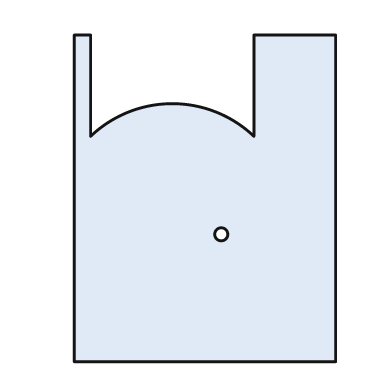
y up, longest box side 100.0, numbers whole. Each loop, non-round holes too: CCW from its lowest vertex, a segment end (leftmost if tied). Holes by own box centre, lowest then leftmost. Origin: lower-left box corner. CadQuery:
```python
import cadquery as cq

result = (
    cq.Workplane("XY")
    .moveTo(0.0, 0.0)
    .lineTo(80.0, 0.0)
    .lineTo(80.0, 100.0)
    .lineTo(55.0, 100.0)
    .lineTo(55.0, 69.0)
    .threePointArc((30.0, 79.0), (5.0, 69.0))
    .lineTo(5.0, 100.0)
    .lineTo(0.0, 100.0)
    .close()
    .moveTo(45.0, 39.0)
    .circle(2.0)
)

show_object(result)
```